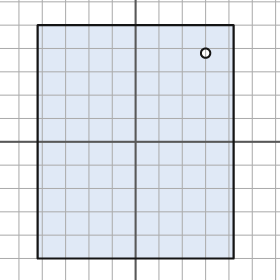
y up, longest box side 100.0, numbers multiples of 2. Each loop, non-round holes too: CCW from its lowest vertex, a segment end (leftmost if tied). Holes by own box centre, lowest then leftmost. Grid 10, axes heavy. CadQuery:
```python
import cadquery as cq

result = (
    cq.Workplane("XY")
    .moveTo(-42.0, -50.0)
    .lineTo(42.0, -50.0)
    .lineTo(42.0, 50.0)
    .lineTo(-42.0, 50.0)
    .close()
    .moveTo(30.0, 38.0)
    .circle(2.0)
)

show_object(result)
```